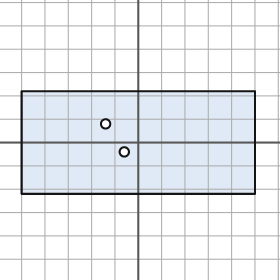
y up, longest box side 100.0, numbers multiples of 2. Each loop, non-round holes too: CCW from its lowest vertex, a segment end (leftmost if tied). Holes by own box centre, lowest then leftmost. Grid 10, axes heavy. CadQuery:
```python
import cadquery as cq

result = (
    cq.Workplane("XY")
    .moveTo(-50.0, -22.0)
    .lineTo(50.0, -22.0)
    .lineTo(50.0, 22.0)
    .lineTo(-50.0, 22.0)
    .close()
    .moveTo(-6.0, -4.0)
    .circle(2.0)
    .moveTo(-14.0, 8.0)
    .circle(2.0)
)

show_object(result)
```